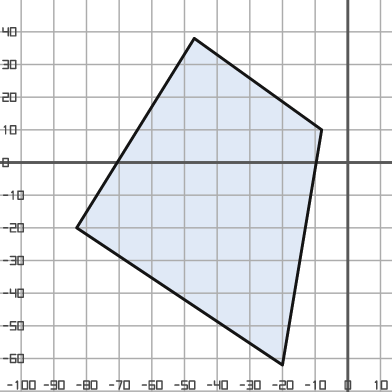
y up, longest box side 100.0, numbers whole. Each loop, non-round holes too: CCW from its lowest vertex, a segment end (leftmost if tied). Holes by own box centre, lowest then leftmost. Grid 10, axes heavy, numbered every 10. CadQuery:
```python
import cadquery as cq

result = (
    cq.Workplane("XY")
    .moveTo(-20.0, -62.0)
    .lineTo(-8.0, 10.0)
    .lineTo(-47.0, 38.0)
    .lineTo(-83.0, -20.0)
    .close()
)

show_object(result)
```